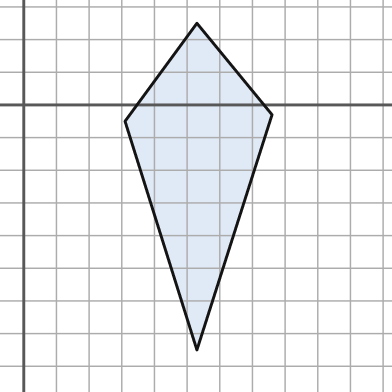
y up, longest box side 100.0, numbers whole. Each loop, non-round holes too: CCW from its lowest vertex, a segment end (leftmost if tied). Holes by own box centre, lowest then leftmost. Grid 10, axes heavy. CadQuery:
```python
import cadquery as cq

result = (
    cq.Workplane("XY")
    .moveTo(53.0, -75.0)
    .lineTo(76.0, -3.0)
    .lineTo(53.0, 25.0)
    .lineTo(31.0, -5.0)
    .close()
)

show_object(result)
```